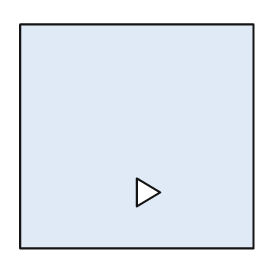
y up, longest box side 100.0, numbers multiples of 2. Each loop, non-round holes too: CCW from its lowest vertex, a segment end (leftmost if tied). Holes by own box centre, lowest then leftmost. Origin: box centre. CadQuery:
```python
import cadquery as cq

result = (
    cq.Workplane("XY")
    .moveTo(-50.0, -48.0)
    .lineTo(50.0, -48.0)
    .lineTo(50.0, 48.0)
    .lineTo(-50.0, 48.0)
    .close()
    .moveTo(0.0, -30.0)
    .lineTo(10.0, -24.0)
    .lineTo(0.0, -18.0)
    .close()
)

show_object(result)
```